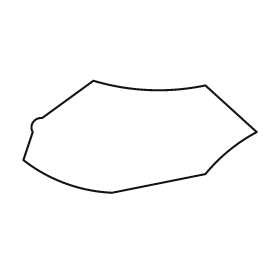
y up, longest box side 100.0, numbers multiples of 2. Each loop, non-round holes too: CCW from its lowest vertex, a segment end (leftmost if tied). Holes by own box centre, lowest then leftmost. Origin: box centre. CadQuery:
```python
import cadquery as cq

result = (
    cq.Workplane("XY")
    .moveTo(-12.0, -24.0)
    .lineTo(28.0, -16.0)
    .threePointArc((38.0, -6.0), (50.0, 2.0))
    .lineTo(28.0, 22.0)
    .threePointArc((4.0, 20.0), (-20.0, 24.0))
    .lineTo(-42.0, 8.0)
    .threePointArc((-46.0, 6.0), (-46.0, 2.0))
    .lineTo(-50.0, -10.0)
    .threePointArc((-32.0, -20.0), (-12.0, -24.0))
    .close()
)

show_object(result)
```